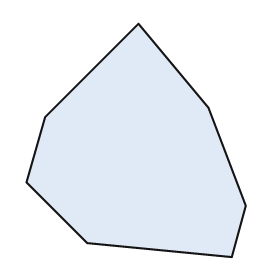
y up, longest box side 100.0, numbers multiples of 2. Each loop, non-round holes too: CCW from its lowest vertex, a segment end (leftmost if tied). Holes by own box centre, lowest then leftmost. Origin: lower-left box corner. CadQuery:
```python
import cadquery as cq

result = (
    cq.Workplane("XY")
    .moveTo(88.0, 0.0)
    .lineTo(94.0, 22.0)
    .lineTo(78.0, 64.0)
    .lineTo(48.0, 100.0)
    .lineTo(8.0, 60.0)
    .lineTo(0.0, 32.0)
    .lineTo(26.0, 6.0)
    .close()
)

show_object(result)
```